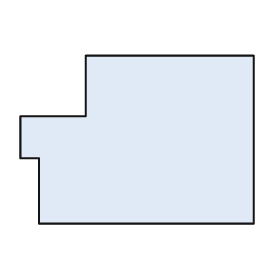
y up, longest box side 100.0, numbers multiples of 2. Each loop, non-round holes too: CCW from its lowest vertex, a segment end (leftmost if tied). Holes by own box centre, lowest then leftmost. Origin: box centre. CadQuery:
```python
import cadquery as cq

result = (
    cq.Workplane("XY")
    .moveTo(-42.0, -36.0)
    .lineTo(50.0, -36.0)
    .lineTo(50.0, 36.0)
    .lineTo(-22.0, 36.0)
    .lineTo(-22.0, 10.0)
    .lineTo(-50.0, 10.0)
    .lineTo(-50.0, -8.0)
    .lineTo(-42.0, -8.0)
    .close()
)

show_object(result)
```